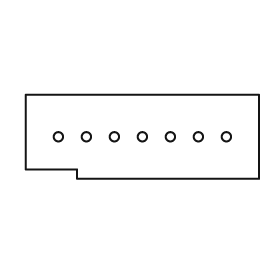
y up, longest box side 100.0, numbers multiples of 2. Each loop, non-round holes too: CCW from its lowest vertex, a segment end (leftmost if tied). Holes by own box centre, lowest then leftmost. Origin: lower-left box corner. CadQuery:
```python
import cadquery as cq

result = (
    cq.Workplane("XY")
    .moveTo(22.0, 0.0)
    .lineTo(100.0, 0.0)
    .lineTo(100.0, 36.0)
    .lineTo(0.0, 36.0)
    .lineTo(0.0, 4.0)
    .lineTo(22.0, 4.0)
    .close()
    .moveTo(14.0, 18.0)
    .circle(2.0)
    .moveTo(26.0, 18.0)
    .circle(2.0)
    .moveTo(38.0, 18.0)
    .circle(2.0)
    .moveTo(50.0, 18.0)
    .circle(2.0)
    .moveTo(62.0, 18.0)
    .circle(2.0)
    .moveTo(74.0, 18.0)
    .circle(2.0)
    .moveTo(86.0, 18.0)
    .circle(2.0)
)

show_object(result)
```